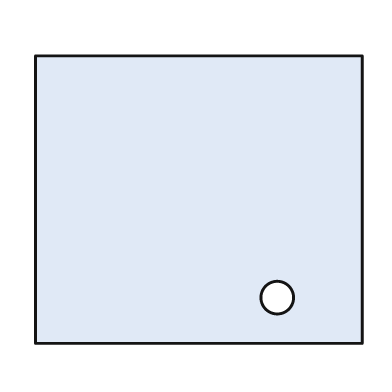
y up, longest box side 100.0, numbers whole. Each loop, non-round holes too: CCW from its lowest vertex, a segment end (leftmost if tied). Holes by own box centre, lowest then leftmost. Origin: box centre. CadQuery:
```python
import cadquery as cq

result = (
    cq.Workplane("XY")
    .moveTo(-50.0, -44.0)
    .lineTo(50.0, -44.0)
    .lineTo(50.0, 44.0)
    .lineTo(-50.0, 44.0)
    .close()
    .moveTo(24.0, -30.0)
    .circle(5.0)
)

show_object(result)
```